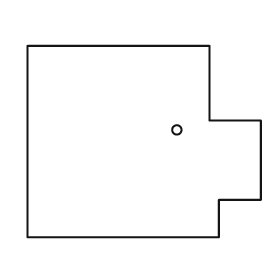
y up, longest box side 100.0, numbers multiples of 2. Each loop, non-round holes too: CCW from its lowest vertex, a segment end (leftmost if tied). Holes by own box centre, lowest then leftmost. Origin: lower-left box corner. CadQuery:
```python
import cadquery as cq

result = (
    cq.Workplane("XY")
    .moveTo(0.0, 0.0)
    .lineTo(82.0, 0.0)
    .lineTo(82.0, 16.0)
    .lineTo(100.0, 16.0)
    .lineTo(100.0, 50.0)
    .lineTo(78.0, 50.0)
    .lineTo(78.0, 82.0)
    .lineTo(0.0, 82.0)
    .close()
    .moveTo(64.0, 46.0)
    .circle(2.0)
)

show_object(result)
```